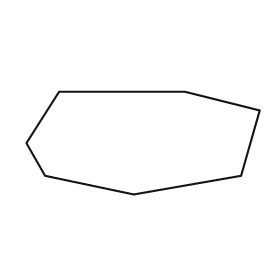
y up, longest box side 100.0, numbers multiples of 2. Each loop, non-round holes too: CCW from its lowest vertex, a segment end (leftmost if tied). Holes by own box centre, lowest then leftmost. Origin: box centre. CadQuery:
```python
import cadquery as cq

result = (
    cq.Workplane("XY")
    .moveTo(-4.0, -22.0)
    .lineTo(42.0, -14.0)
    .lineTo(50.0, 14.0)
    .lineTo(18.0, 22.0)
    .lineTo(-36.0, 22.0)
    .lineTo(-50.0, 0.0)
    .lineTo(-42.0, -14.0)
    .close()
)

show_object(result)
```